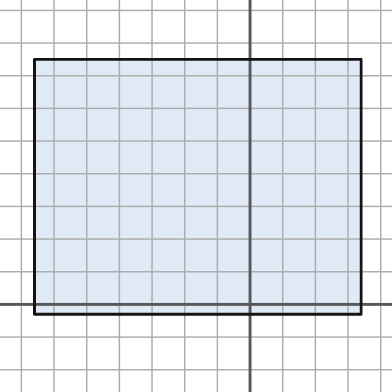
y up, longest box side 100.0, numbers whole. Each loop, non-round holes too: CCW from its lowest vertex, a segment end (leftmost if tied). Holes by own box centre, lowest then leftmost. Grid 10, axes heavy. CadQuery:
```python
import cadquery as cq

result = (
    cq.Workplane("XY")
    .moveTo(-66.0, -3.0)
    .lineTo(34.0, -3.0)
    .lineTo(34.0, 75.0)
    .lineTo(-66.0, 75.0)
    .close()
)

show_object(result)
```